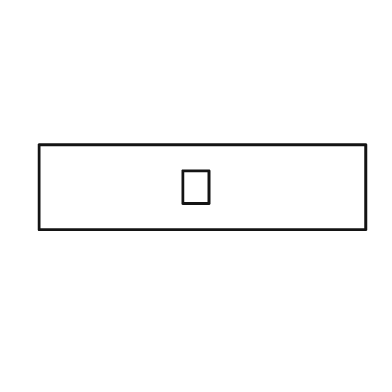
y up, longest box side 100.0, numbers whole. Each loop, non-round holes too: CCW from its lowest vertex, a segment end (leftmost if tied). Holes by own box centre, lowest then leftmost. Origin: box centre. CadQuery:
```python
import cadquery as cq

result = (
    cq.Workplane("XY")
    .moveTo(-50.0, -13.0)
    .lineTo(50.0, -13.0)
    .lineTo(50.0, 13.0)
    .lineTo(-50.0, 13.0)
    .close()
    .moveTo(-6.0, -5.0)
    .lineTo(2.0, -5.0)
    .lineTo(2.0, 5.0)
    .lineTo(-6.0, 5.0)
    .close()
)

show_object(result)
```